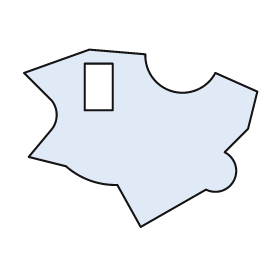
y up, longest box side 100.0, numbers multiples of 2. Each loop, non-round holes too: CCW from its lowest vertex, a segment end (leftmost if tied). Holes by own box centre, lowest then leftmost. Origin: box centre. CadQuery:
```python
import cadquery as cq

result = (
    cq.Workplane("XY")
    .moveTo(0.0, -38.0)
    .lineTo(28.0, -22.0)
    .threePointArc((40.0, -18.0), (36.0, -6.0))
    .lineTo(46.0, 4.0)
    .lineTo(50.0, 20.0)
    .lineTo(32.0, 28.0)
    .threePointArc((14.0, 20.0), (2.0, 36.0))
    .lineTo(-22.0, 38.0)
    .lineTo(-50.0, 28.0)
    .lineTo(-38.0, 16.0)
    .threePointArc((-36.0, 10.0), (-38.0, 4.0))
    .lineTo(-48.0, -8.0)
    .lineTo(-32.0, -12.0)
    .threePointArc((-22.0, -18.0), (-10.0, -20.0))
    .close()
    .moveTo(-24.0, 12.0)
    .lineTo(-12.0, 12.0)
    .lineTo(-12.0, 32.0)
    .lineTo(-24.0, 32.0)
    .close()
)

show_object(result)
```